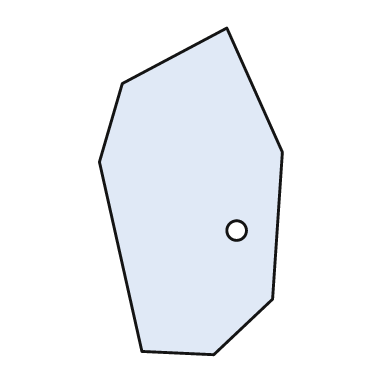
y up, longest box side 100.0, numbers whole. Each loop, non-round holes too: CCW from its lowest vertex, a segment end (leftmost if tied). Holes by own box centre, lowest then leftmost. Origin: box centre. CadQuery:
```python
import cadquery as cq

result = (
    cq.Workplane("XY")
    .moveTo(7.0, -50.0)
    .lineTo(25.0, -33.0)
    .lineTo(28.0, 12.0)
    .lineTo(11.0, 50.0)
    .lineTo(-21.0, 33.0)
    .lineTo(-28.0, 9.0)
    .lineTo(-15.0, -49.0)
    .close()
    .moveTo(14.0, -12.0)
    .circle(3.0)
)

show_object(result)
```